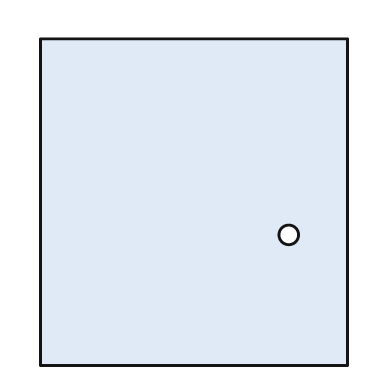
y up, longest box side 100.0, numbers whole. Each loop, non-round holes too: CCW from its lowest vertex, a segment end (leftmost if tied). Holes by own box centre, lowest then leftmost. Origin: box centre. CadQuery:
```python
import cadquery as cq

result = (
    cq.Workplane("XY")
    .moveTo(-47.0, -50.0)
    .lineTo(47.0, -50.0)
    .lineTo(47.0, 50.0)
    .lineTo(-47.0, 50.0)
    .close()
    .moveTo(29.0, -10.0)
    .circle(3.0)
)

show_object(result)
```